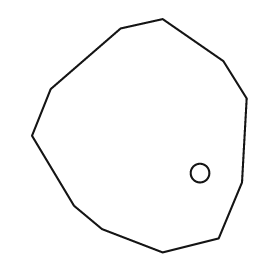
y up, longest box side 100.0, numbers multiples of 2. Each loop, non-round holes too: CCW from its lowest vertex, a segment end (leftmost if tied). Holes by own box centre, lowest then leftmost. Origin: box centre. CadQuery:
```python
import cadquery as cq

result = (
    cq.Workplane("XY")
    .moveTo(10.0, -50.0)
    .lineTo(34.0, -44.0)
    .lineTo(44.0, -20.0)
    .lineTo(46.0, 16.0)
    .lineTo(36.0, 32.0)
    .lineTo(10.0, 50.0)
    .lineTo(-8.0, 46.0)
    .lineTo(-38.0, 20.0)
    .lineTo(-46.0, 0.0)
    .lineTo(-28.0, -30.0)
    .lineTo(-16.0, -40.0)
    .close()
    .moveTo(26.0, -16.0)
    .circle(4.0)
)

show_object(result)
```